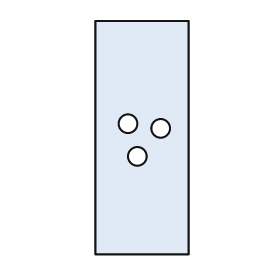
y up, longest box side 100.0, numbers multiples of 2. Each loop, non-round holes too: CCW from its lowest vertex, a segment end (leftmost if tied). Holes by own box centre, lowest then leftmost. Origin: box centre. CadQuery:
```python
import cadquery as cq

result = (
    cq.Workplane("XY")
    .moveTo(-20.0, -50.0)
    .lineTo(20.0, -50.0)
    .lineTo(20.0, 50.0)
    .lineTo(-20.0, 50.0)
    .close()
    .moveTo(-2.0, -8.0)
    .circle(4.0)
    .moveTo(8.0, 4.0)
    .circle(4.0)
    .moveTo(-6.0, 6.0)
    .circle(4.0)
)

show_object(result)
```